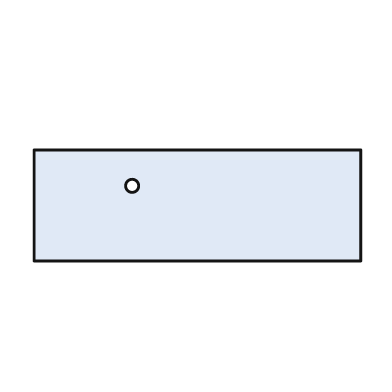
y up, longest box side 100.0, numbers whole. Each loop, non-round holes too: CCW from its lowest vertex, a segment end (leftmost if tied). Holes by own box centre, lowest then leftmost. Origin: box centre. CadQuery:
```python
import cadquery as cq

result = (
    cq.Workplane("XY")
    .moveTo(-50.0, -17.0)
    .lineTo(50.0, -17.0)
    .lineTo(50.0, 17.0)
    .lineTo(-50.0, 17.0)
    .close()
    .moveTo(-20.0, 6.0)
    .circle(2.0)
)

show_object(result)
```